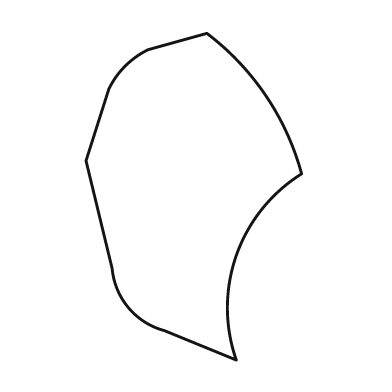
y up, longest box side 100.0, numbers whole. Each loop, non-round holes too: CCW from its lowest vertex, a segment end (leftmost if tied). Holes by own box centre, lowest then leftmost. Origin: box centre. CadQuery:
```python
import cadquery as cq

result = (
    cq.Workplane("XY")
    .moveTo(13.0, -50.0)
    .threePointArc((13.0, -18.0), (33.0, 7.0))
    .threePointArc((22.0, 31.0), (4.0, 50.0))
    .lineTo(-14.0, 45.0)
    .threePointArc((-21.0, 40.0), (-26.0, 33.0))
    .lineTo(-33.0, 11.0)
    .lineTo(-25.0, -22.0)
    .threePointArc((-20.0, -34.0), (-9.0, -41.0))
    .close()
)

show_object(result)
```